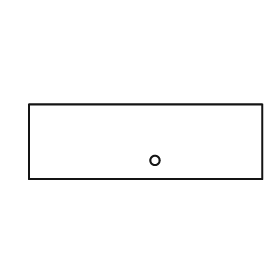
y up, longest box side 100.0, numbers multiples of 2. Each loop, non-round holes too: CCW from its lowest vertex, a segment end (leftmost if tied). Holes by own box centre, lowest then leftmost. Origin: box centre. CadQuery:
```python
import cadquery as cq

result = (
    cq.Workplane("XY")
    .moveTo(-50.0, -16.0)
    .lineTo(50.0, -16.0)
    .lineTo(50.0, 16.0)
    .lineTo(-50.0, 16.0)
    .close()
    .moveTo(4.0, -8.0)
    .circle(2.0)
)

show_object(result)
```